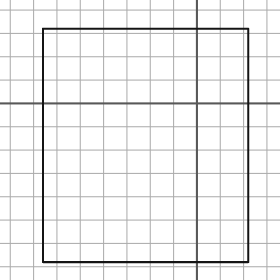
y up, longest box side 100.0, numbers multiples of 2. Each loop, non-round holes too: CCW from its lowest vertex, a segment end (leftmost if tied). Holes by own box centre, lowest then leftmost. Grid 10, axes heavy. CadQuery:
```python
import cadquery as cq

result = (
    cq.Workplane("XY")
    .moveTo(-66.0, -68.0)
    .lineTo(22.0, -68.0)
    .lineTo(22.0, 32.0)
    .lineTo(-66.0, 32.0)
    .close()
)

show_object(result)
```